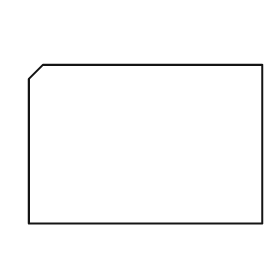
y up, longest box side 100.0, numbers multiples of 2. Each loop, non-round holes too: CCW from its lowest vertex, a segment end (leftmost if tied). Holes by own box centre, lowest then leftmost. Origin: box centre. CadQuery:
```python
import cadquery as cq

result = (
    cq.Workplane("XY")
    .moveTo(-50.0, -34.0)
    .lineTo(50.0, -34.0)
    .lineTo(50.0, 34.0)
    .lineTo(-44.0, 34.0)
    .lineTo(-50.0, 28.0)
    .close()
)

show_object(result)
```